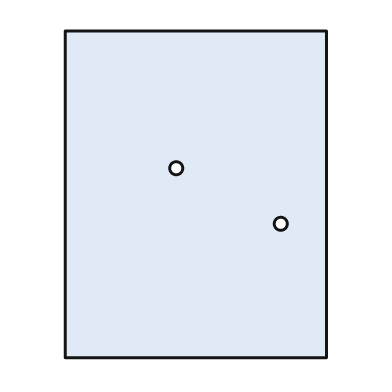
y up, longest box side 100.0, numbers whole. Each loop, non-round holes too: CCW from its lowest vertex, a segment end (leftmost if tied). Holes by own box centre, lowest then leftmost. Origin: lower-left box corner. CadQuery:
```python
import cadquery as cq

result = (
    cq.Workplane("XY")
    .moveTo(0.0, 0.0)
    .lineTo(80.0, 0.0)
    .lineTo(80.0, 100.0)
    .lineTo(0.0, 100.0)
    .close()
    .moveTo(66.0, 41.0)
    .circle(2.0)
    .moveTo(34.0, 58.0)
    .circle(2.0)
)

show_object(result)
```